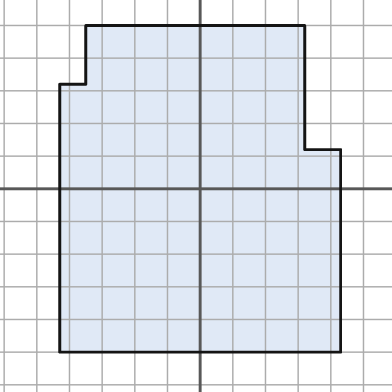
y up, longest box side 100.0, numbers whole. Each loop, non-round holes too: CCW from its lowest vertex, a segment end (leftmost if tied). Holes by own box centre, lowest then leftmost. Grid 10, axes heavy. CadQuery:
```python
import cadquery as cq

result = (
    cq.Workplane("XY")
    .moveTo(-43.0, -50.0)
    .lineTo(43.0, -50.0)
    .lineTo(43.0, 12.0)
    .lineTo(32.0, 12.0)
    .lineTo(32.0, 50.0)
    .lineTo(-35.0, 50.0)
    .lineTo(-35.0, 32.0)
    .lineTo(-43.0, 32.0)
    .close()
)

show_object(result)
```